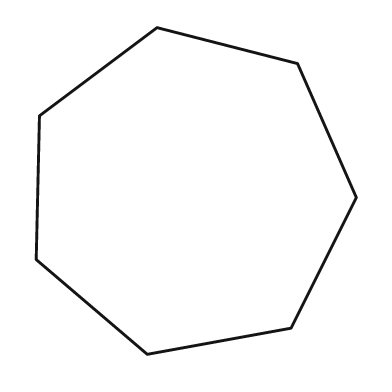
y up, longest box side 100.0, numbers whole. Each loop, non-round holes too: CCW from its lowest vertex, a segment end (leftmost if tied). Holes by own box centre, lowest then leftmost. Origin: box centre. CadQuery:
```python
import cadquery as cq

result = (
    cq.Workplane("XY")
    .moveTo(-15.0, -50.0)
    .lineTo(29.0, -42.0)
    .lineTo(49.0, -2.0)
    .lineTo(31.0, 39.0)
    .lineTo(-12.0, 50.0)
    .lineTo(-48.0, 23.0)
    .lineTo(-49.0, -21.0)
    .close()
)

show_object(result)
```